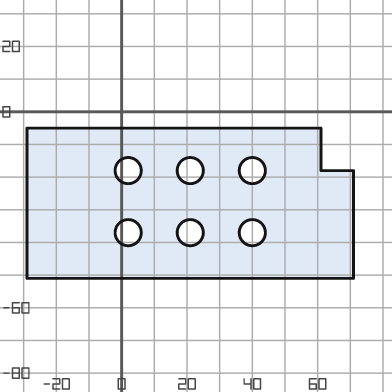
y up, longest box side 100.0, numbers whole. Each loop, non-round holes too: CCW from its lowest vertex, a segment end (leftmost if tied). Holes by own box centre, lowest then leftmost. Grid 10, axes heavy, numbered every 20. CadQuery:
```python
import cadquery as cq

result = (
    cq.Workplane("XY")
    .moveTo(-29.0, -51.0)
    .lineTo(71.0, -51.0)
    .lineTo(71.0, -18.0)
    .lineTo(61.0, -18.0)
    .lineTo(61.0, -5.0)
    .lineTo(-29.0, -5.0)
    .close()
    .moveTo(2.0, -37.0)
    .circle(4.0)
    .moveTo(21.0, -37.0)
    .circle(4.0)
    .moveTo(40.0, -37.0)
    .circle(4.0)
    .moveTo(2.0, -18.0)
    .circle(4.0)
    .moveTo(21.0, -18.0)
    .circle(4.0)
    .moveTo(40.0, -18.0)
    .circle(4.0)
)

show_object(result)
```